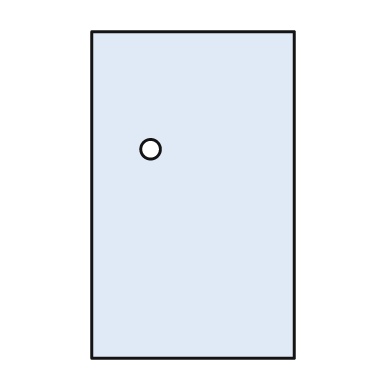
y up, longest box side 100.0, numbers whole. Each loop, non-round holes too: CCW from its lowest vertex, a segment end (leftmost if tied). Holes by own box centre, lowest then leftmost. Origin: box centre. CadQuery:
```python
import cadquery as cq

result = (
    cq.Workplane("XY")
    .moveTo(-31.0, -50.0)
    .lineTo(31.0, -50.0)
    .lineTo(31.0, 50.0)
    .lineTo(-31.0, 50.0)
    .close()
    .moveTo(-13.0, 14.0)
    .circle(3.0)
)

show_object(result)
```